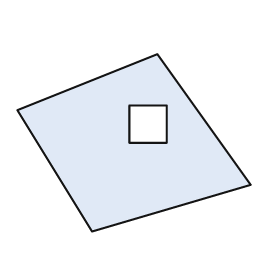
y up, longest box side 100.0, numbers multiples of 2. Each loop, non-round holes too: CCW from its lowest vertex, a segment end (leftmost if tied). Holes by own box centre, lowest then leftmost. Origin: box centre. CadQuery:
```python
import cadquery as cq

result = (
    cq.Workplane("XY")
    .moveTo(-18.0, -38.0)
    .lineTo(50.0, -18.0)
    .lineTo(10.0, 38.0)
    .lineTo(-50.0, 14.0)
    .close()
    .moveTo(-2.0, 0.0)
    .lineTo(14.0, 0.0)
    .lineTo(14.0, 16.0)
    .lineTo(-2.0, 16.0)
    .close()
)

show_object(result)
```